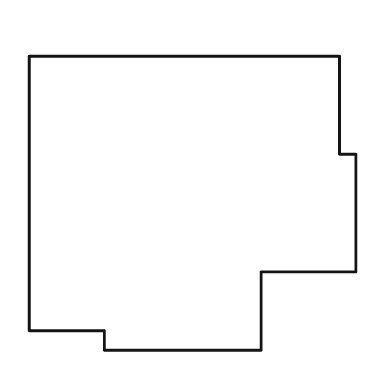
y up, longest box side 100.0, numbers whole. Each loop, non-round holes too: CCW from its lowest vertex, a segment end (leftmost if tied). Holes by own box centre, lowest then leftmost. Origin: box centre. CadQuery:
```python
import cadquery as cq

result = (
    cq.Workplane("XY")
    .moveTo(-27.0, -45.0)
    .lineTo(21.0, -45.0)
    .lineTo(21.0, -21.0)
    .lineTo(50.0, -21.0)
    .lineTo(50.0, 15.0)
    .lineTo(45.0, 15.0)
    .lineTo(45.0, 45.0)
    .lineTo(-50.0, 45.0)
    .lineTo(-50.0, -39.0)
    .lineTo(-27.0, -39.0)
    .close()
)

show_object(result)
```